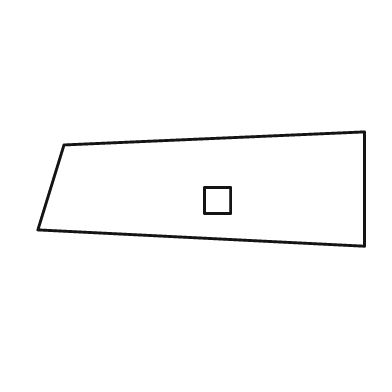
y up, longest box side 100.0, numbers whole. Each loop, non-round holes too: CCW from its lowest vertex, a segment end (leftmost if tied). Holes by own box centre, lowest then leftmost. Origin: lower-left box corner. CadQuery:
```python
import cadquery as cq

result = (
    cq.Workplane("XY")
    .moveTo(100.0, 0.0)
    .lineTo(100.0, 35.0)
    .lineTo(8.0, 31.0)
    .lineTo(0.0, 5.0)
    .close()
    .moveTo(51.0, 10.0)
    .lineTo(59.0, 10.0)
    .lineTo(59.0, 18.0)
    .lineTo(51.0, 18.0)
    .close()
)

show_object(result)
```